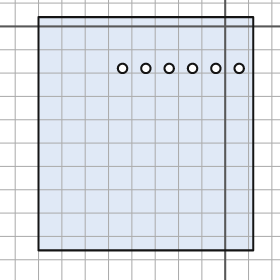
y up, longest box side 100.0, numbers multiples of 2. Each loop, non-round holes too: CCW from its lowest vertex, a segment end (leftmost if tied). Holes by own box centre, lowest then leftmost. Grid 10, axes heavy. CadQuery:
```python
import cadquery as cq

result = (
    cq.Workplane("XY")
    .moveTo(-80.0, -96.0)
    .lineTo(12.0, -96.0)
    .lineTo(12.0, 4.0)
    .lineTo(-80.0, 4.0)
    .close()
    .moveTo(-44.0, -18.0)
    .circle(2.0)
    .moveTo(-34.0, -18.0)
    .circle(2.0)
    .moveTo(-24.0, -18.0)
    .circle(2.0)
    .moveTo(-14.0, -18.0)
    .circle(2.0)
    .moveTo(-4.0, -18.0)
    .circle(2.0)
    .moveTo(6.0, -18.0)
    .circle(2.0)
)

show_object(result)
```